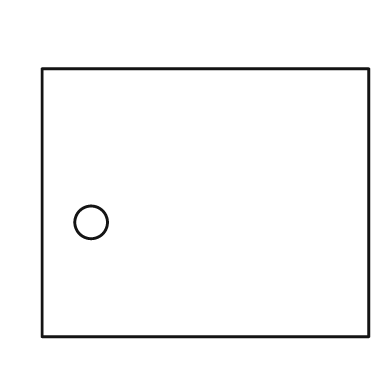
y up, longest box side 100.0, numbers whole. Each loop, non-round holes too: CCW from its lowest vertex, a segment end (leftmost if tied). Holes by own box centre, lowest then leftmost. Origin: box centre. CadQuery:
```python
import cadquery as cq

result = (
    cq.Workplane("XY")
    .moveTo(-50.0, -41.0)
    .lineTo(50.0, -41.0)
    .lineTo(50.0, 41.0)
    .lineTo(-50.0, 41.0)
    .close()
    .moveTo(-35.0, -6.0)
    .circle(5.0)
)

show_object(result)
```